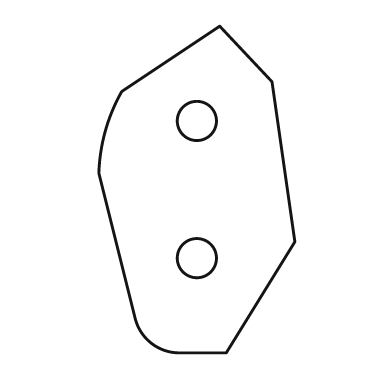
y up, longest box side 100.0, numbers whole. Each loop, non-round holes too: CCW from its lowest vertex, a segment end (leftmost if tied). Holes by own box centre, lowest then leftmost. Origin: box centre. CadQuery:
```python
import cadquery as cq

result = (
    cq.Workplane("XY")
    .moveTo(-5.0, -50.0)
    .lineTo(9.0, -50.0)
    .lineTo(30.0, -16.0)
    .lineTo(23.0, 33.0)
    .lineTo(7.0, 50.0)
    .lineTo(-23.0, 30.0)
    .threePointArc((-28.0, 18.0), (-30.0, 5.0))
    .lineTo(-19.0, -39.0)
    .threePointArc((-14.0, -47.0), (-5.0, -50.0))
    .close()
    .moveTo(0.0, -21.0)
    .circle(6.0)
    .moveTo(0.0, 21.0)
    .circle(6.0)
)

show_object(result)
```